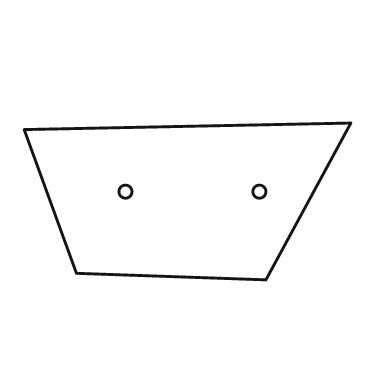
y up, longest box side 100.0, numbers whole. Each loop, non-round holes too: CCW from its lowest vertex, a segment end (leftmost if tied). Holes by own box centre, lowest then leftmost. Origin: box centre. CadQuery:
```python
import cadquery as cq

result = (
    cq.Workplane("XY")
    .moveTo(24.0, -24.0)
    .lineTo(50.0, 24.0)
    .lineTo(-50.0, 22.0)
    .lineTo(-34.0, -22.0)
    .close()
    .moveTo(-19.0, 3.0)
    .circle(2.0)
    .moveTo(22.0, 3.0)
    .circle(2.0)
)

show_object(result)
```